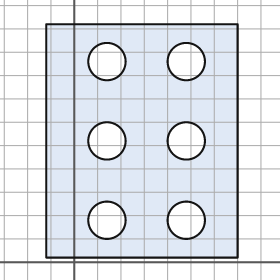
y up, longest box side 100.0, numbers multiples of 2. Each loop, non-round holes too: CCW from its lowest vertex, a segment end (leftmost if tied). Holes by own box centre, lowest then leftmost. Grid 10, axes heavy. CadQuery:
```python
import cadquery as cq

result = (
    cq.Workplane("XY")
    .moveTo(-12.0, 2.0)
    .lineTo(70.0, 2.0)
    .lineTo(70.0, 102.0)
    .lineTo(-12.0, 102.0)
    .close()
    .moveTo(14.0, 18.0)
    .circle(8.0)
    .moveTo(48.0, 18.0)
    .circle(8.0)
    .moveTo(14.0, 52.0)
    .circle(8.0)
    .moveTo(48.0, 52.0)
    .circle(8.0)
    .moveTo(14.0, 86.0)
    .circle(8.0)
    .moveTo(48.0, 86.0)
    .circle(8.0)
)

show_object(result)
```